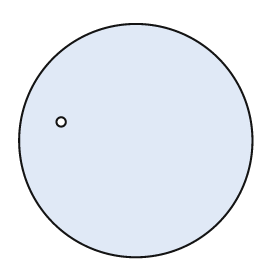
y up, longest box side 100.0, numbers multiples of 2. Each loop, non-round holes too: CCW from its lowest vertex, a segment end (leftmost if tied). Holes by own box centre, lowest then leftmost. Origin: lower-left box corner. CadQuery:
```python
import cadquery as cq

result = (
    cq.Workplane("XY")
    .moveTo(50.0, 50.0)
    .circle(50.0)
    .moveTo(18.0, 58.0)
    .circle(2.0)
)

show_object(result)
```